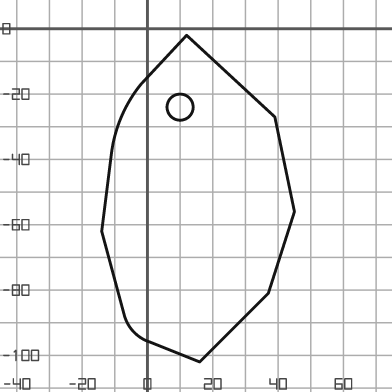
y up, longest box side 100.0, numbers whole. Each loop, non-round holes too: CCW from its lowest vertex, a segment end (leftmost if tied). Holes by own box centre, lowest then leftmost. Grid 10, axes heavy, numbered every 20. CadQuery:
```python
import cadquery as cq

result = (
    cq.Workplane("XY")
    .moveTo(16.0, -102.0)
    .lineTo(37.0, -81.0)
    .lineTo(45.0, -56.0)
    .lineTo(39.0, -27.0)
    .lineTo(12.0, -2.0)
    .lineTo(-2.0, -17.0)
    .threePointArc((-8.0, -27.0), (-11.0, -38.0))
    .lineTo(-14.0, -62.0)
    .lineTo(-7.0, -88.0)
    .threePointArc((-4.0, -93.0), (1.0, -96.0))
    .close()
    .moveTo(10.0, -24.0)
    .circle(4.0)
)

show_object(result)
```